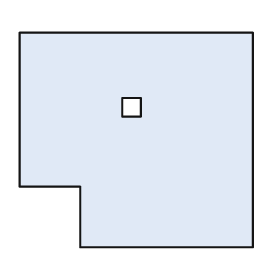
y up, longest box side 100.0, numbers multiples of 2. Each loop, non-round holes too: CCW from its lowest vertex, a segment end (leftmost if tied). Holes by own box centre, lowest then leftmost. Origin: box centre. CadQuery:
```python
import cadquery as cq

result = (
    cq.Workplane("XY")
    .moveTo(-24.0, -46.0)
    .lineTo(50.0, -46.0)
    .lineTo(50.0, 46.0)
    .lineTo(-50.0, 46.0)
    .lineTo(-50.0, -20.0)
    .lineTo(-24.0, -20.0)
    .close()
    .moveTo(-6.0, 10.0)
    .lineTo(2.0, 10.0)
    .lineTo(2.0, 18.0)
    .lineTo(-6.0, 18.0)
    .close()
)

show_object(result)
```